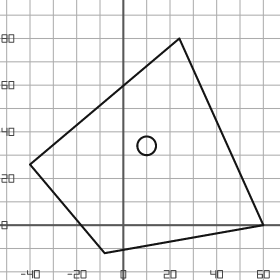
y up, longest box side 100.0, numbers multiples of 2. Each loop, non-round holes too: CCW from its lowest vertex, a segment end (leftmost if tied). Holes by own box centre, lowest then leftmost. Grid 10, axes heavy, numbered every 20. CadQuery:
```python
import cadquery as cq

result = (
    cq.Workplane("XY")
    .moveTo(-8.0, -12.0)
    .lineTo(60.0, 0.0)
    .lineTo(24.0, 80.0)
    .lineTo(-40.0, 26.0)
    .close()
    .moveTo(10.0, 34.0)
    .circle(4.0)
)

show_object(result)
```